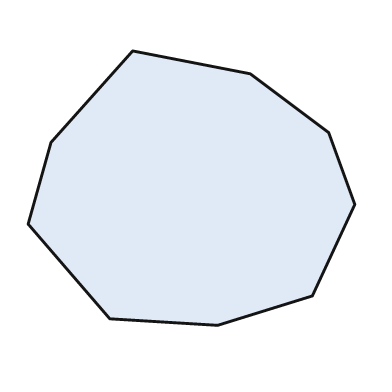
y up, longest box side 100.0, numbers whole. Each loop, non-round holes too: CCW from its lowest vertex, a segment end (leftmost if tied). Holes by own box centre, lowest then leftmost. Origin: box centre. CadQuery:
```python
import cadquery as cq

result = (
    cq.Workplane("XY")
    .moveTo(8.0, -42.0)
    .lineTo(37.0, -33.0)
    .lineTo(50.0, -5.0)
    .lineTo(42.0, 17.0)
    .lineTo(18.0, 35.0)
    .lineTo(-18.0, 42.0)
    .lineTo(-43.0, 14.0)
    .lineTo(-50.0, -11.0)
    .lineTo(-25.0, -40.0)
    .close()
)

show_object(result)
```